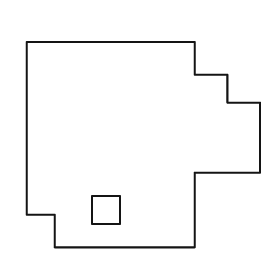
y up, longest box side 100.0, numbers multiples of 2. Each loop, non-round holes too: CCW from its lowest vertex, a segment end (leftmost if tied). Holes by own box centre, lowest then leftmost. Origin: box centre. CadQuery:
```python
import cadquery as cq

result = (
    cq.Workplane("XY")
    .moveTo(-38.0, -44.0)
    .lineTo(22.0, -44.0)
    .lineTo(22.0, -12.0)
    .lineTo(50.0, -12.0)
    .lineTo(50.0, 18.0)
    .lineTo(36.0, 18.0)
    .lineTo(36.0, 30.0)
    .lineTo(22.0, 30.0)
    .lineTo(22.0, 44.0)
    .lineTo(-50.0, 44.0)
    .lineTo(-50.0, -30.0)
    .lineTo(-38.0, -30.0)
    .close()
    .moveTo(-22.0, -34.0)
    .lineTo(-10.0, -34.0)
    .lineTo(-10.0, -22.0)
    .lineTo(-22.0, -22.0)
    .close()
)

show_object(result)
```